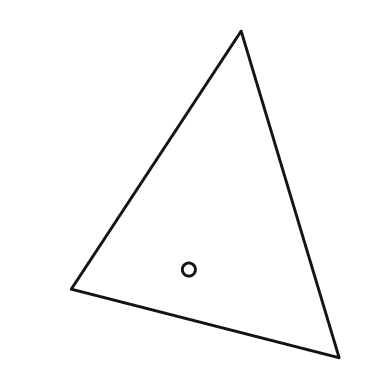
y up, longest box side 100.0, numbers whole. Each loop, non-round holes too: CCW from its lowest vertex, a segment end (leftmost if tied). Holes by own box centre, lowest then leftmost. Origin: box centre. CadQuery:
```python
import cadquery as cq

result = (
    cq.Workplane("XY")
    .moveTo(41.0, -50.0)
    .lineTo(11.0, 50.0)
    .lineTo(-41.0, -29.0)
    .close()
    .moveTo(-5.0, -23.0)
    .circle(2.0)
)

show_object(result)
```